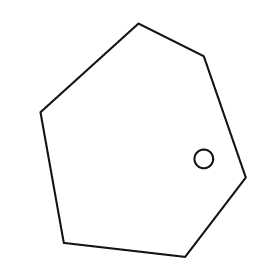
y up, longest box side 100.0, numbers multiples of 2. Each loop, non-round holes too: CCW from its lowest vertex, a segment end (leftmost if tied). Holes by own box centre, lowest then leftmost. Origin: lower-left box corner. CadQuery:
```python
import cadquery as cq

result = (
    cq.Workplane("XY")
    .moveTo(62.0, 0.0)
    .lineTo(88.0, 34.0)
    .lineTo(70.0, 86.0)
    .lineTo(42.0, 100.0)
    .lineTo(0.0, 62.0)
    .lineTo(10.0, 6.0)
    .close()
    .moveTo(70.0, 42.0)
    .circle(4.0)
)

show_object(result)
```